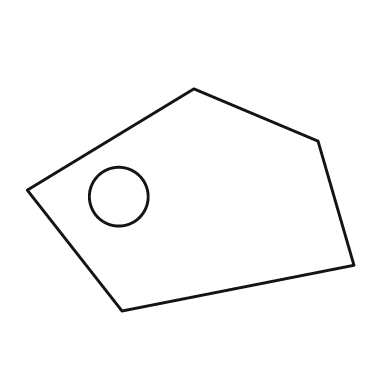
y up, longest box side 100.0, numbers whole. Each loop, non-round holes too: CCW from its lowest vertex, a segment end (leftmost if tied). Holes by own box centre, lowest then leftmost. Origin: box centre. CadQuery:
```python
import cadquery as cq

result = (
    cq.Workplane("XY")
    .moveTo(-21.0, -34.0)
    .lineTo(50.0, -20.0)
    .lineTo(39.0, 18.0)
    .lineTo(1.0, 34.0)
    .lineTo(-50.0, 3.0)
    .close()
    .moveTo(-22.0, 1.0)
    .circle(9.0)
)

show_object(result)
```